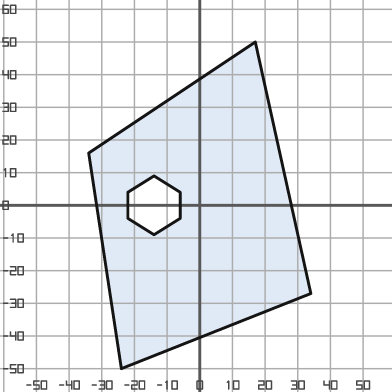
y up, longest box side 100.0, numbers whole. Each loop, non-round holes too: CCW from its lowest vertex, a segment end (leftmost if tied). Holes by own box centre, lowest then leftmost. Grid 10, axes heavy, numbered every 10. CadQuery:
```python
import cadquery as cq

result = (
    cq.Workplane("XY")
    .moveTo(-24.0, -50.0)
    .lineTo(34.0, -27.0)
    .lineTo(17.0, 50.0)
    .lineTo(-34.0, 16.0)
    .close()
    .moveTo(-14.0, -9.0)
    .lineTo(-6.0, -4.0)
    .lineTo(-6.0, 4.0)
    .lineTo(-14.0, 9.0)
    .lineTo(-22.0, 4.0)
    .lineTo(-22.0, -4.0)
    .close()
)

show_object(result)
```